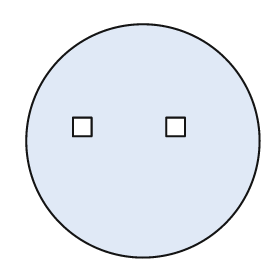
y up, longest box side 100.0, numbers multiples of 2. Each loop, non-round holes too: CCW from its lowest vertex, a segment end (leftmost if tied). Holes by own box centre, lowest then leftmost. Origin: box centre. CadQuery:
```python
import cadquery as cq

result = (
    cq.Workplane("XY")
    .moveTo(0.0, 0.0)
    .circle(50.0)
    .moveTo(-30.0, 2.0)
    .lineTo(-22.0, 2.0)
    .lineTo(-22.0, 10.0)
    .lineTo(-30.0, 10.0)
    .close()
    .moveTo(10.0, 2.0)
    .lineTo(18.0, 2.0)
    .lineTo(18.0, 10.0)
    .lineTo(10.0, 10.0)
    .close()
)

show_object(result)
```